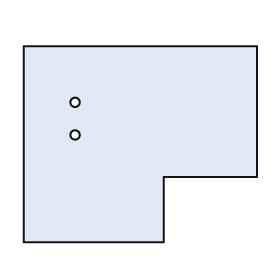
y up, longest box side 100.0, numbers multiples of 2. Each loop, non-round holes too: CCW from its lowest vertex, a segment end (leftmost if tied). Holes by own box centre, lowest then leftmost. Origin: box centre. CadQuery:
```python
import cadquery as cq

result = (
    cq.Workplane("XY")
    .moveTo(-50.0, -42.0)
    .lineTo(10.0, -42.0)
    .lineTo(10.0, -14.0)
    .lineTo(50.0, -14.0)
    .lineTo(50.0, 42.0)
    .lineTo(-50.0, 42.0)
    .close()
    .moveTo(-28.0, 4.0)
    .circle(2.0)
    .moveTo(-28.0, 18.0)
    .circle(2.0)
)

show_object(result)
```